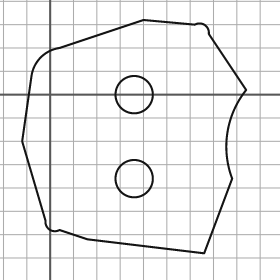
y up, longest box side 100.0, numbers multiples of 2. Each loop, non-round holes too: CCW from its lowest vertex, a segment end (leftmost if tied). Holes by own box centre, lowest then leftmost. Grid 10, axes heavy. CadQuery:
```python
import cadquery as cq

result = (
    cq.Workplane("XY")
    .moveTo(66.0, -68.0)
    .lineTo(78.0, -36.0)
    .threePointArc((76.0, -16.0), (84.0, 2.0))
    .lineTo(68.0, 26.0)
    .threePointArc((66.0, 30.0), (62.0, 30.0))
    .lineTo(40.0, 32.0)
    .lineTo(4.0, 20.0)
    .threePointArc((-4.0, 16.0), (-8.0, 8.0))
    .lineTo(-12.0, -20.0)
    .lineTo(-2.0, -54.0)
    .threePointArc((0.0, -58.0), (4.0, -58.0))
    .lineTo(16.0, -62.0)
    .close()
    .moveTo(36.0, -36.0)
    .circle(8.0)
    .moveTo(36.0, 0.0)
    .circle(8.0)
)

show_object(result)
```